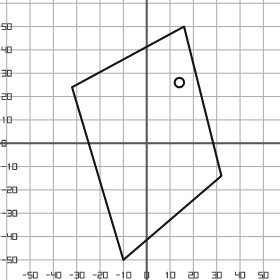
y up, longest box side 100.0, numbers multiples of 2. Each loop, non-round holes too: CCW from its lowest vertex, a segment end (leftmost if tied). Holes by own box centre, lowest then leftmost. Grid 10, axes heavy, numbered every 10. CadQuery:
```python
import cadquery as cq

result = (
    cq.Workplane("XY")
    .moveTo(-10.0, -50.0)
    .lineTo(32.0, -14.0)
    .lineTo(16.0, 50.0)
    .lineTo(-32.0, 24.0)
    .close()
    .moveTo(14.0, 26.0)
    .circle(2.0)
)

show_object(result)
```